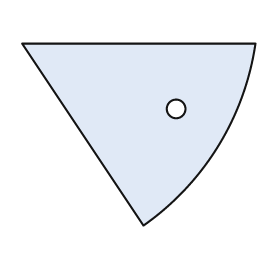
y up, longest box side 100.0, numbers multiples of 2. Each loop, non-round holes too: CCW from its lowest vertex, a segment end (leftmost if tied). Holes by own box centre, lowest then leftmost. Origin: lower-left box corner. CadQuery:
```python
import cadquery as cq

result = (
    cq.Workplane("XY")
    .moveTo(52.0, 0.0)
    .threePointArc((84.0, 34.0), (100.0, 78.0))
    .lineTo(0.0, 78.0)
    .close()
    .moveTo(66.0, 50.0)
    .circle(4.0)
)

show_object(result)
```